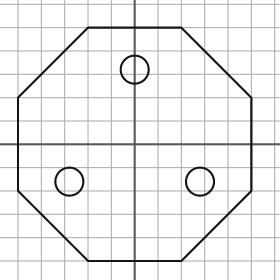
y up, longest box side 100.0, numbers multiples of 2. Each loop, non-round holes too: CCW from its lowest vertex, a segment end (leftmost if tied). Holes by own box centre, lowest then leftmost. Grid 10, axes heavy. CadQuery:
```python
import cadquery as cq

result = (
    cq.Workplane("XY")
    .moveTo(-20.0, -50.0)
    .lineTo(20.0, -50.0)
    .lineTo(50.0, -20.0)
    .lineTo(50.0, 20.0)
    .lineTo(20.0, 50.0)
    .lineTo(-20.0, 50.0)
    .lineTo(-50.0, 20.0)
    .lineTo(-50.0, -20.0)
    .close()
    .moveTo(-28.0, -16.0)
    .circle(6.0)
    .moveTo(28.0, -16.0)
    .circle(6.0)
    .moveTo(0.0, 32.0)
    .circle(6.0)
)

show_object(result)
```